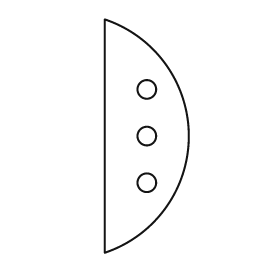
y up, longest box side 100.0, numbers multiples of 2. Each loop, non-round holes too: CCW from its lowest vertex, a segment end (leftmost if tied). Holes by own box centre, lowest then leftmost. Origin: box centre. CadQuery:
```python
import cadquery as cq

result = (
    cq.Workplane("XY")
    .moveTo(-18.0, -50.0)
    .threePointArc((18.0, 0.0), (-18.0, 50.0))
    .close()
    .moveTo(0.0, -20.0)
    .circle(4.0)
    .moveTo(0.0, 0.0)
    .circle(4.0)
    .moveTo(0.0, 20.0)
    .circle(4.0)
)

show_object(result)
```